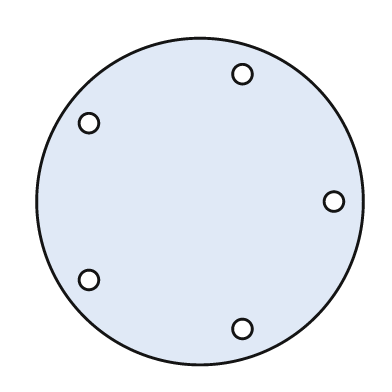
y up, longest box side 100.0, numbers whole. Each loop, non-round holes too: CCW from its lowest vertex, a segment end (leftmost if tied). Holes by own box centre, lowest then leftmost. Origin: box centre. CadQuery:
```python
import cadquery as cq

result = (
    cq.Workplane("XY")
    .moveTo(0.0, 0.0)
    .circle(50.0)
    .moveTo(13.0, -39.0)
    .circle(3.0)
    .moveTo(-34.0, -24.0)
    .circle(3.0)
    .moveTo(41.0, 0.0)
    .circle(3.0)
    .moveTo(-34.0, 24.0)
    .circle(3.0)
    .moveTo(13.0, 39.0)
    .circle(3.0)
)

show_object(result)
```